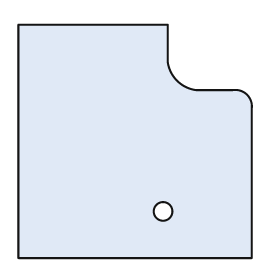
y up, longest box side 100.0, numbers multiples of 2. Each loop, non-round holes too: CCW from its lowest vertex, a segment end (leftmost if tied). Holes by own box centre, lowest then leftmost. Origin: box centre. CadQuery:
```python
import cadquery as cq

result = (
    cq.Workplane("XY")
    .moveTo(-50.0, -50.0)
    .lineTo(50.0, -50.0)
    .lineTo(50.0, 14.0)
    .threePointArc((48.0, 20.0), (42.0, 22.0))
    .lineTo(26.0, 22.0)
    .threePointArc((18.0, 26.0), (14.0, 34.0))
    .lineTo(14.0, 50.0)
    .lineTo(-50.0, 50.0)
    .close()
    .moveTo(12.0, -30.0)
    .circle(4.0)
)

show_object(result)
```